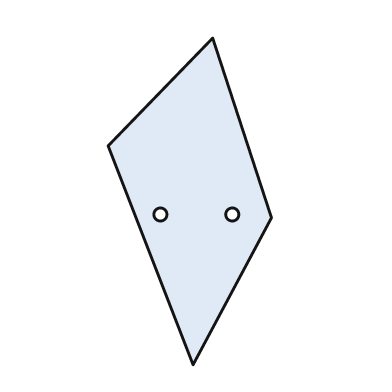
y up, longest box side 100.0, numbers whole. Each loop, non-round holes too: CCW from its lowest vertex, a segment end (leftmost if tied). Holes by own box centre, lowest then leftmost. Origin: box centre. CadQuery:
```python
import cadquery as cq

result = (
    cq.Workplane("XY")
    .moveTo(1.0, -50.0)
    .lineTo(25.0, -5.0)
    .lineTo(7.0, 50.0)
    .lineTo(-25.0, 17.0)
    .close()
    .moveTo(-9.0, -4.0)
    .circle(2.0)
    .moveTo(13.0, -4.0)
    .circle(2.0)
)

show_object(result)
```